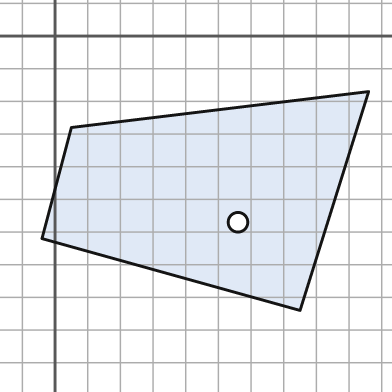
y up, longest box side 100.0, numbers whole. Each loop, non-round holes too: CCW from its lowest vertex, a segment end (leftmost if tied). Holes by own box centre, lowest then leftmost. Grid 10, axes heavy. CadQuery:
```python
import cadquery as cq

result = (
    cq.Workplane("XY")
    .moveTo(75.0, -84.0)
    .lineTo(96.0, -17.0)
    .lineTo(5.0, -28.0)
    .lineTo(-4.0, -62.0)
    .close()
    .moveTo(56.0, -57.0)
    .circle(3.0)
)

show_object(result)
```